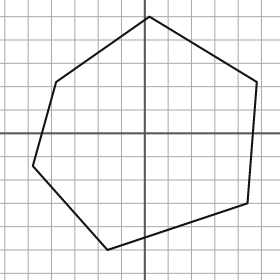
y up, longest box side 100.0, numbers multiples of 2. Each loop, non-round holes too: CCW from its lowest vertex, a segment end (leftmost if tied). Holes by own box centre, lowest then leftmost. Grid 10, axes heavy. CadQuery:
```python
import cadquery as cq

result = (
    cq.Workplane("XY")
    .moveTo(-16.0, -50.0)
    .lineTo(44.0, -30.0)
    .lineTo(48.0, 22.0)
    .lineTo(2.0, 50.0)
    .lineTo(-38.0, 22.0)
    .lineTo(-48.0, -14.0)
    .close()
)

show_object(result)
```